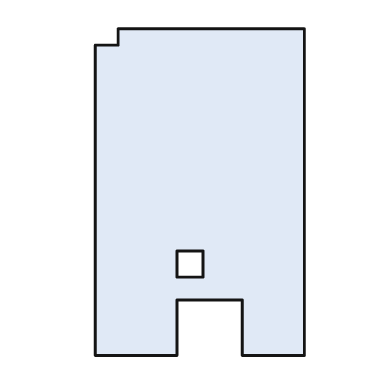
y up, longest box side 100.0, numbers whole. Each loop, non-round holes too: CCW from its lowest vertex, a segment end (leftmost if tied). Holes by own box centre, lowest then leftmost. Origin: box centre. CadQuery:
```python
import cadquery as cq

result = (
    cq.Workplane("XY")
    .moveTo(-32.0, -50.0)
    .lineTo(-7.0, -50.0)
    .lineTo(-7.0, -33.0)
    .lineTo(13.0, -33.0)
    .lineTo(13.0, -50.0)
    .lineTo(32.0, -50.0)
    .lineTo(32.0, 50.0)
    .lineTo(-25.0, 50.0)
    .lineTo(-25.0, 45.0)
    .lineTo(-32.0, 45.0)
    .close()
    .moveTo(-7.0, -26.0)
    .lineTo(1.0, -26.0)
    .lineTo(1.0, -18.0)
    .lineTo(-7.0, -18.0)
    .close()
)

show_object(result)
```